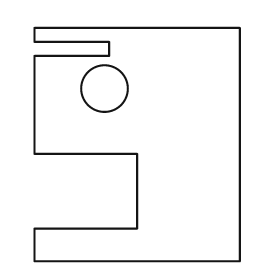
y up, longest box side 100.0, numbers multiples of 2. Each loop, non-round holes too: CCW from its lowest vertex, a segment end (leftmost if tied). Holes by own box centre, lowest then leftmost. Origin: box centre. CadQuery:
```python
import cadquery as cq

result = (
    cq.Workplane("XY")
    .moveTo(-44.0, -50.0)
    .lineTo(44.0, -50.0)
    .lineTo(44.0, 50.0)
    .lineTo(-44.0, 50.0)
    .lineTo(-44.0, 44.0)
    .lineTo(-12.0, 44.0)
    .lineTo(-12.0, 38.0)
    .lineTo(-44.0, 38.0)
    .lineTo(-44.0, -4.0)
    .lineTo(0.0, -4.0)
    .lineTo(0.0, -36.0)
    .lineTo(-44.0, -36.0)
    .close()
    .moveTo(-14.0, 24.0)
    .circle(10.0)
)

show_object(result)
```